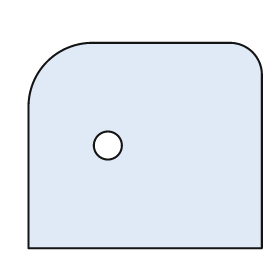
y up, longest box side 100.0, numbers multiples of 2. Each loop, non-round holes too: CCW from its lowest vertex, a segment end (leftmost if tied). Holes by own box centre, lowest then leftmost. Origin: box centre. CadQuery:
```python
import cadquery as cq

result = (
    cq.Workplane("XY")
    .moveTo(-50.0, -44.0)
    .lineTo(50.0, -44.0)
    .lineTo(50.0, 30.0)
    .threePointArc((46.0, 40.0), (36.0, 44.0))
    .lineTo(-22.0, 44.0)
    .threePointArc((-42.0, 36.0), (-50.0, 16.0))
    .close()
    .moveTo(-16.0, 0.0)
    .circle(6.0)
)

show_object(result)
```